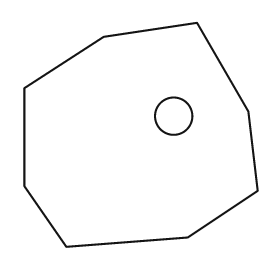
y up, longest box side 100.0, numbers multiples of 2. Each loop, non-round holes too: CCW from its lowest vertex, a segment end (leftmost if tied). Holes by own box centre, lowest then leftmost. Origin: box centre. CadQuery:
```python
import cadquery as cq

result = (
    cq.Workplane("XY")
    .moveTo(-32.0, -48.0)
    .lineTo(20.0, -44.0)
    .lineTo(50.0, -24.0)
    .lineTo(46.0, 10.0)
    .lineTo(24.0, 48.0)
    .lineTo(-16.0, 42.0)
    .lineTo(-50.0, 20.0)
    .lineTo(-50.0, -22.0)
    .close()
    .moveTo(14.0, 8.0)
    .circle(8.0)
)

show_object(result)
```